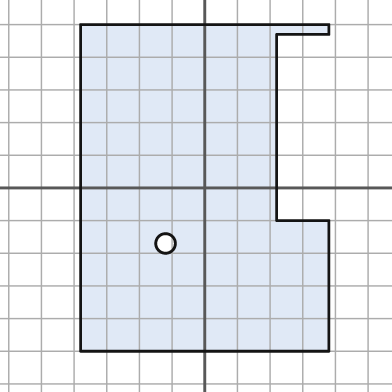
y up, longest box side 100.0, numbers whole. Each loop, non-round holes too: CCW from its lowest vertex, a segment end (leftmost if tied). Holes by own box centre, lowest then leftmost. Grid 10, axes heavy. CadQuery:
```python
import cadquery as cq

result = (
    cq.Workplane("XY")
    .moveTo(-38.0, -50.0)
    .lineTo(38.0, -50.0)
    .lineTo(38.0, -10.0)
    .lineTo(22.0, -10.0)
    .lineTo(22.0, 47.0)
    .lineTo(38.0, 47.0)
    .lineTo(38.0, 50.0)
    .lineTo(-38.0, 50.0)
    .close()
    .moveTo(-12.0, -17.0)
    .circle(3.0)
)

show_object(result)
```